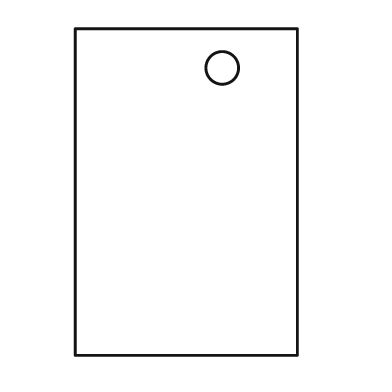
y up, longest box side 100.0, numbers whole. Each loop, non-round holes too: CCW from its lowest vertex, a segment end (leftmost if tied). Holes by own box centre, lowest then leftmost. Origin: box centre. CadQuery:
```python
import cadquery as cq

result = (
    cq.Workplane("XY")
    .moveTo(-34.0, -50.0)
    .lineTo(34.0, -50.0)
    .lineTo(34.0, 50.0)
    .lineTo(-34.0, 50.0)
    .close()
    .moveTo(11.0, 38.0)
    .circle(5.0)
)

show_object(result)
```